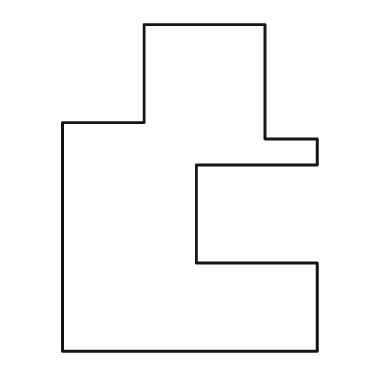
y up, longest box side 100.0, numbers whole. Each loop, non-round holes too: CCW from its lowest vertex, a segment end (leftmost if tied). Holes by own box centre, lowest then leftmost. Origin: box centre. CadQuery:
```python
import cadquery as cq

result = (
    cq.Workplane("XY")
    .moveTo(-39.0, -50.0)
    .lineTo(39.0, -50.0)
    .lineTo(39.0, -23.0)
    .lineTo(2.0, -23.0)
    .lineTo(2.0, 7.0)
    .lineTo(39.0, 7.0)
    .lineTo(39.0, 15.0)
    .lineTo(23.0, 15.0)
    .lineTo(23.0, 50.0)
    .lineTo(-14.0, 50.0)
    .lineTo(-14.0, 20.0)
    .lineTo(-39.0, 20.0)
    .close()
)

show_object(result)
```